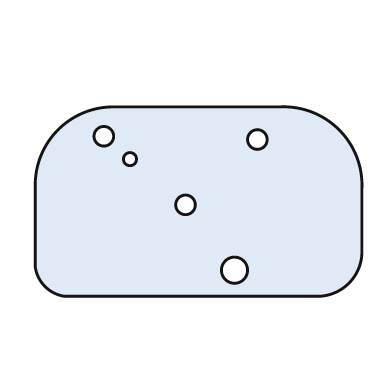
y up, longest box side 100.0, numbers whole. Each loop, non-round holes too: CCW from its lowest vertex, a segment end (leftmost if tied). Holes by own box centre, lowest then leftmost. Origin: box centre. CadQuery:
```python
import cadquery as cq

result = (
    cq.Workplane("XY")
    .moveTo(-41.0, -29.0)
    .lineTo(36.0, -29.0)
    .threePointArc((46.0, -25.0), (50.0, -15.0))
    .lineTo(50.0, 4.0)
    .threePointArc((43.0, 22.0), (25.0, 29.0))
    .lineTo(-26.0, 29.0)
    .threePointArc((-43.0, 22.0), (-50.0, 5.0))
    .lineTo(-50.0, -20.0)
    .threePointArc((-47.0, -26.0), (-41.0, -29.0))
    .close()
    .moveTo(11.0, -21.0)
    .circle(4.0)
    .moveTo(-4.0, -1.0)
    .circle(3.0)
    .moveTo(-21.0, 13.0)
    .circle(2.0)
    .moveTo(18.0, 19.0)
    .circle(3.0)
    .moveTo(-29.0, 20.0)
    .circle(3.0)
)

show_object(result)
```